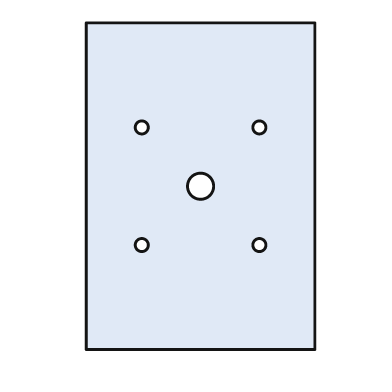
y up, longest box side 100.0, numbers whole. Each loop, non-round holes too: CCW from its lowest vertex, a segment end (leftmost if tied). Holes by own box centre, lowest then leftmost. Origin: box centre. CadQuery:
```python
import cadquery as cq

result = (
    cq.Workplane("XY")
    .moveTo(-35.0, -50.0)
    .lineTo(35.0, -50.0)
    .lineTo(35.0, 50.0)
    .lineTo(-35.0, 50.0)
    .close()
    .moveTo(-18.0, -18.0)
    .circle(2.0)
    .moveTo(18.0, -18.0)
    .circle(2.0)
    .moveTo(0.0, 0.0)
    .circle(4.0)
    .moveTo(-18.0, 18.0)
    .circle(2.0)
    .moveTo(18.0, 18.0)
    .circle(2.0)
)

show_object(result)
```